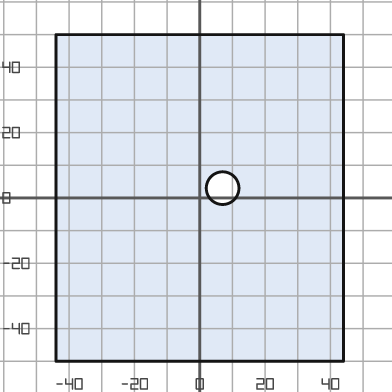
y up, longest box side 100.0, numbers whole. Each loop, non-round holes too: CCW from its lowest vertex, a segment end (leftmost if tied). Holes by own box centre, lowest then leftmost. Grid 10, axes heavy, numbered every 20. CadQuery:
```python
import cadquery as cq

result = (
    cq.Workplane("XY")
    .moveTo(-44.0, -50.0)
    .lineTo(44.0, -50.0)
    .lineTo(44.0, 50.0)
    .lineTo(-44.0, 50.0)
    .close()
    .moveTo(7.0, 3.0)
    .circle(5.0)
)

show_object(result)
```